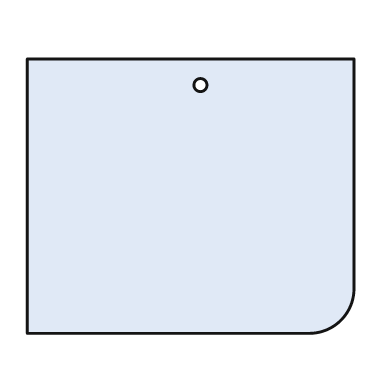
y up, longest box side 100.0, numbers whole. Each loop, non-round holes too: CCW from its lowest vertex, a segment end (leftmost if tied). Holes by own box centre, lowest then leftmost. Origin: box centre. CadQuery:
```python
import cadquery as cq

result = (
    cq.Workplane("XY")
    .moveTo(-50.0, -42.0)
    .lineTo(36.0, -42.0)
    .threePointArc((46.0, -38.0), (50.0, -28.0))
    .lineTo(50.0, 42.0)
    .lineTo(-50.0, 42.0)
    .close()
    .moveTo(3.0, 34.0)
    .circle(2.0)
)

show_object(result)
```